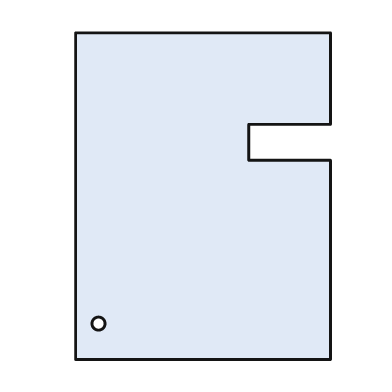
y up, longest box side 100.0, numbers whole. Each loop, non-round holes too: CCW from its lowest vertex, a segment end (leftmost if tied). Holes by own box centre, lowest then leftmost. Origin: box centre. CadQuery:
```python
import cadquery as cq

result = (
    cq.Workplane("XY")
    .moveTo(-39.0, -50.0)
    .lineTo(39.0, -50.0)
    .lineTo(39.0, 11.0)
    .lineTo(14.0, 11.0)
    .lineTo(14.0, 22.0)
    .lineTo(39.0, 22.0)
    .lineTo(39.0, 50.0)
    .lineTo(-39.0, 50.0)
    .close()
    .moveTo(-32.0, -39.0)
    .circle(2.0)
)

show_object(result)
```